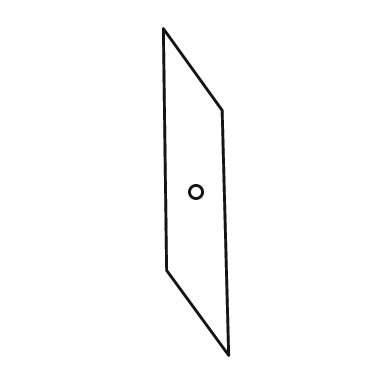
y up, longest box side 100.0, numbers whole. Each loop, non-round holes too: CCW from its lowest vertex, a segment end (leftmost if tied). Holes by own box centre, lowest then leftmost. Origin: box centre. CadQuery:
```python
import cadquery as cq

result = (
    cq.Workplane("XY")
    .moveTo(10.0, -50.0)
    .lineTo(8.0, 25.0)
    .lineTo(-10.0, 50.0)
    .lineTo(-9.0, -24.0)
    .close()
    .moveTo(0.0, 0.0)
    .circle(2.0)
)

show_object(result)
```